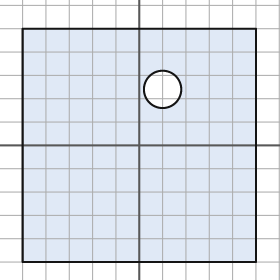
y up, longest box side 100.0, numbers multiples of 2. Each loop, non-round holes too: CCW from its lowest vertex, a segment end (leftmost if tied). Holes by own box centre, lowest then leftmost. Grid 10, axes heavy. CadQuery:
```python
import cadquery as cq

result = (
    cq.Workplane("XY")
    .moveTo(-50.0, -50.0)
    .lineTo(50.0, -50.0)
    .lineTo(50.0, 50.0)
    .lineTo(-50.0, 50.0)
    .close()
    .moveTo(10.0, 24.0)
    .circle(8.0)
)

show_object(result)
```